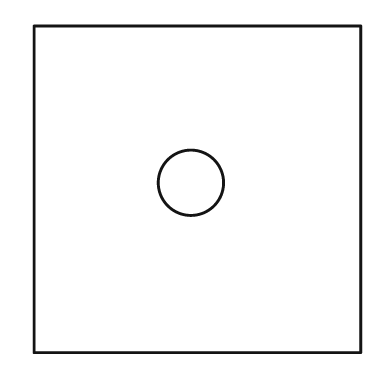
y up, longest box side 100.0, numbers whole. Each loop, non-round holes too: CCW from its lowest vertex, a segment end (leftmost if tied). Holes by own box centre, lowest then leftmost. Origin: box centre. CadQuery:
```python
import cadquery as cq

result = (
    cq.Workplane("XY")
    .moveTo(-50.0, -50.0)
    .lineTo(50.0, -50.0)
    .lineTo(50.0, 50.0)
    .lineTo(-50.0, 50.0)
    .close()
    .moveTo(-2.0, 2.0)
    .circle(10.0)
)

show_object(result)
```